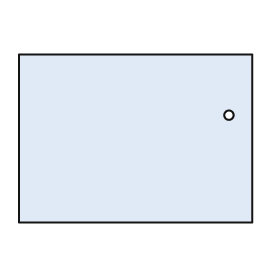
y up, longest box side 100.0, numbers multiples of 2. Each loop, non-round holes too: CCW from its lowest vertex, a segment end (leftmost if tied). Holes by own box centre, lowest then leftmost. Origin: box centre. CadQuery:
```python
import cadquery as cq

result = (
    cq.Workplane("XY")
    .moveTo(-50.0, -36.0)
    .lineTo(50.0, -36.0)
    .lineTo(50.0, 36.0)
    .lineTo(-50.0, 36.0)
    .close()
    .moveTo(40.0, 10.0)
    .circle(2.0)
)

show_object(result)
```